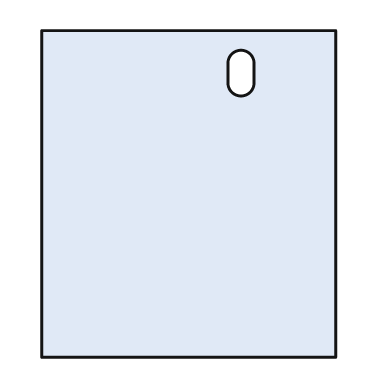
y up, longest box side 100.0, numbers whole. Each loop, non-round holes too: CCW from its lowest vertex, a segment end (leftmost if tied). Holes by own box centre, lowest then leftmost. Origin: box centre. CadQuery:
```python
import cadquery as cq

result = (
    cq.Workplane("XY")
    .moveTo(-45.0, -50.0)
    .lineTo(45.0, -50.0)
    .lineTo(45.0, 50.0)
    .lineTo(-45.0, 50.0)
    .close()
    .moveTo(12.0, 34.0)
    .threePointArc((16.0, 30.0), (20.0, 34.0))
    .lineTo(20.0, 40.0)
    .threePointArc((16.0, 44.0), (12.0, 40.0))
    .close()
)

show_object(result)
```